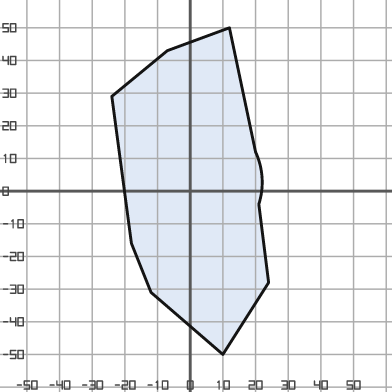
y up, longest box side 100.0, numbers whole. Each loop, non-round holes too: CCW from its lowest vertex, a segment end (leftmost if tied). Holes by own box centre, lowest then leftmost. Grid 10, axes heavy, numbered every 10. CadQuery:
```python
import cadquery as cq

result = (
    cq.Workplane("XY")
    .moveTo(10.0, -50.0)
    .lineTo(24.0, -28.0)
    .lineTo(21.0, -4.0)
    .threePointArc((22.0, 4.0), (20.0, 12.0))
    .lineTo(12.0, 50.0)
    .lineTo(-7.0, 43.0)
    .lineTo(-24.0, 29.0)
    .lineTo(-18.0, -16.0)
    .lineTo(-12.0, -31.0)
    .close()
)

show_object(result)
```